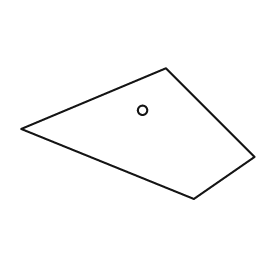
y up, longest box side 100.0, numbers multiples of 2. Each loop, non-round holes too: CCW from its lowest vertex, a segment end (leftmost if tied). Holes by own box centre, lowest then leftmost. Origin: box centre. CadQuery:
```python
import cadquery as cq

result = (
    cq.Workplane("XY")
    .moveTo(24.0, -28.0)
    .lineTo(50.0, -10.0)
    .lineTo(12.0, 28.0)
    .lineTo(-50.0, 2.0)
    .close()
    .moveTo(2.0, 10.0)
    .circle(2.0)
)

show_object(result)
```